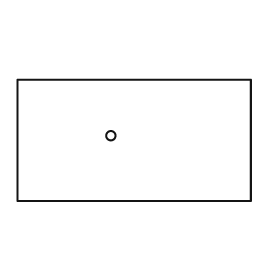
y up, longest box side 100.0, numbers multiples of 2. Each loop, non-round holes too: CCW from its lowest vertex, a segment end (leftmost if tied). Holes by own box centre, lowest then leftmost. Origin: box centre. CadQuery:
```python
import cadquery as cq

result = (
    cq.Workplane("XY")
    .moveTo(-50.0, -26.0)
    .lineTo(50.0, -26.0)
    .lineTo(50.0, 26.0)
    .lineTo(-50.0, 26.0)
    .close()
    .moveTo(-10.0, 2.0)
    .circle(2.0)
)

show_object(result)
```